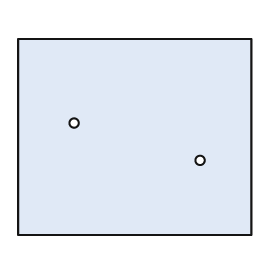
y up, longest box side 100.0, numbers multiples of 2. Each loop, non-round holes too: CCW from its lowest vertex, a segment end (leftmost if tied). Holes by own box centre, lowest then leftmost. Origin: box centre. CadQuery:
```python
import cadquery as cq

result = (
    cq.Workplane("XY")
    .moveTo(-50.0, -42.0)
    .lineTo(50.0, -42.0)
    .lineTo(50.0, 42.0)
    .lineTo(-50.0, 42.0)
    .close()
    .moveTo(28.0, -10.0)
    .circle(2.0)
    .moveTo(-26.0, 6.0)
    .circle(2.0)
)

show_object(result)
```